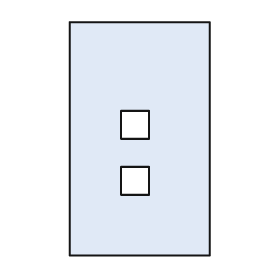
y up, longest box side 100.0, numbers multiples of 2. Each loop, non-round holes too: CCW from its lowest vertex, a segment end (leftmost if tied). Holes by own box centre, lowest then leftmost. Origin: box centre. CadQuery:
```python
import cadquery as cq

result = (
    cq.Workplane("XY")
    .moveTo(-30.0, -50.0)
    .lineTo(30.0, -50.0)
    .lineTo(30.0, 50.0)
    .lineTo(-30.0, 50.0)
    .close()
    .moveTo(-8.0, -24.0)
    .lineTo(4.0, -24.0)
    .lineTo(4.0, -12.0)
    .lineTo(-8.0, -12.0)
    .close()
    .moveTo(-8.0, 0.0)
    .lineTo(4.0, 0.0)
    .lineTo(4.0, 12.0)
    .lineTo(-8.0, 12.0)
    .close()
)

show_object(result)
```